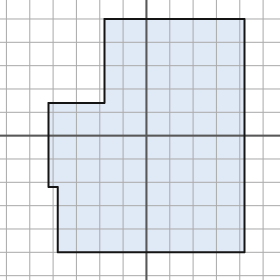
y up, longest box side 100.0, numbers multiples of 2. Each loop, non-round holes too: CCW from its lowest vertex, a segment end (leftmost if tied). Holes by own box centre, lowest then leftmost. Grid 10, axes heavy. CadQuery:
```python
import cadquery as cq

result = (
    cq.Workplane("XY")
    .moveTo(-38.0, -50.0)
    .lineTo(42.0, -50.0)
    .lineTo(42.0, 50.0)
    .lineTo(-18.0, 50.0)
    .lineTo(-18.0, 14.0)
    .lineTo(-42.0, 14.0)
    .lineTo(-42.0, -22.0)
    .lineTo(-38.0, -22.0)
    .close()
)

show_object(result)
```